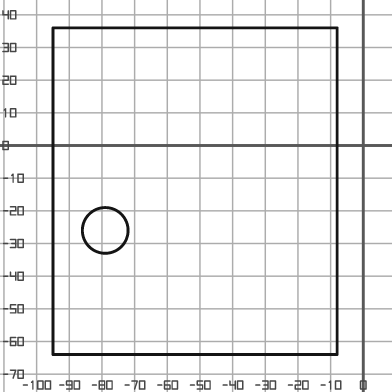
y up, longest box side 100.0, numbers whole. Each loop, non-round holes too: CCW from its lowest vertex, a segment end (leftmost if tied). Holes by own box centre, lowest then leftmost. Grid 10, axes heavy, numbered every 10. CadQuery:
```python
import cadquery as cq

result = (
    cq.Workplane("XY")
    .moveTo(-95.0, -64.0)
    .lineTo(-8.0, -64.0)
    .lineTo(-8.0, 36.0)
    .lineTo(-95.0, 36.0)
    .close()
    .moveTo(-79.0, -26.0)
    .circle(7.0)
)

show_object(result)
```